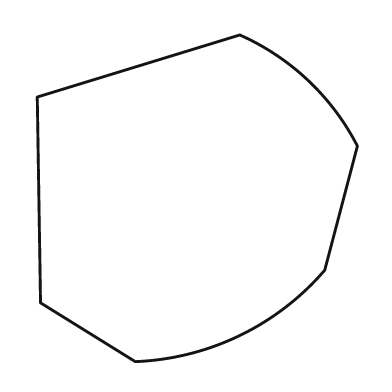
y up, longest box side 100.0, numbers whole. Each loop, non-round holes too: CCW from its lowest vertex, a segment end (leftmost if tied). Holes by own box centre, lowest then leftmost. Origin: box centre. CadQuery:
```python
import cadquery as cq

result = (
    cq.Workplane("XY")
    .moveTo(-19.0, -50.0)
    .threePointArc((13.0, -42.0), (39.0, -22.0))
    .lineTo(49.0, 16.0)
    .threePointArc((34.0, 36.0), (13.0, 50.0))
    .lineTo(-49.0, 31.0)
    .lineTo(-48.0, -32.0)
    .close()
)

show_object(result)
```